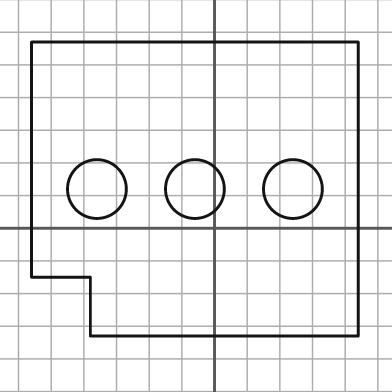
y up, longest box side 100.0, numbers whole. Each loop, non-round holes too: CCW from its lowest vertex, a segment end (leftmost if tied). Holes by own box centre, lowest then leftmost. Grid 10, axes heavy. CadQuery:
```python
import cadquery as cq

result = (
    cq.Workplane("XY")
    .moveTo(-38.0, -33.0)
    .lineTo(44.0, -33.0)
    .lineTo(44.0, 57.0)
    .lineTo(-56.0, 57.0)
    .lineTo(-56.0, -15.0)
    .lineTo(-38.0, -15.0)
    .close()
    .moveTo(-36.0, 12.0)
    .circle(9.0)
    .moveTo(-6.0, 12.0)
    .circle(9.0)
    .moveTo(24.0, 12.0)
    .circle(9.0)
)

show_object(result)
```